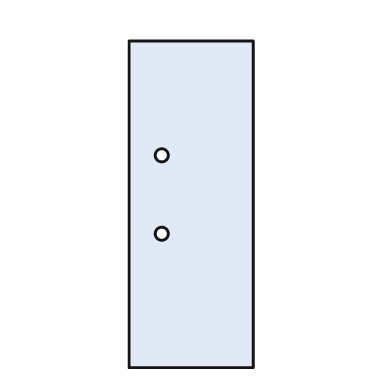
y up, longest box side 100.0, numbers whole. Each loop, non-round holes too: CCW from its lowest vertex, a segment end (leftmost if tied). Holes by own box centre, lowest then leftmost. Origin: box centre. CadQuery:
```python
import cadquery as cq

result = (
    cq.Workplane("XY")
    .moveTo(-19.0, -50.0)
    .lineTo(19.0, -50.0)
    .lineTo(19.0, 50.0)
    .lineTo(-19.0, 50.0)
    .close()
    .moveTo(-9.0, -9.0)
    .circle(2.0)
    .moveTo(-9.0, 15.0)
    .circle(2.0)
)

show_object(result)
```